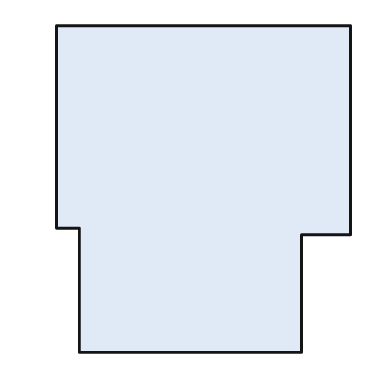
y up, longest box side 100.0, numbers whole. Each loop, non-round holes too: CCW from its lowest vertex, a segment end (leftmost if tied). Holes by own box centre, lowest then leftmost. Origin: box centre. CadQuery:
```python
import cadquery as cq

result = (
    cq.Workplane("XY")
    .moveTo(-38.0, -50.0)
    .lineTo(30.0, -50.0)
    .lineTo(30.0, -14.0)
    .lineTo(45.0, -14.0)
    .lineTo(45.0, 50.0)
    .lineTo(-45.0, 50.0)
    .lineTo(-45.0, -12.0)
    .lineTo(-38.0, -12.0)
    .close()
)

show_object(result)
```